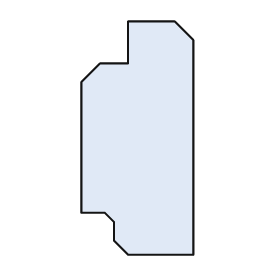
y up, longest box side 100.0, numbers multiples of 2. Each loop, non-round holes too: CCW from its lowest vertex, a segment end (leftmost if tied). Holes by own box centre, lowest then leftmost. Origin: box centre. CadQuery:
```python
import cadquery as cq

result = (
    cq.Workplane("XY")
    .moveTo(-4.0, -50.0)
    .lineTo(24.0, -50.0)
    .lineTo(24.0, 42.0)
    .lineTo(16.0, 50.0)
    .lineTo(-4.0, 50.0)
    .lineTo(-4.0, 32.0)
    .lineTo(-16.0, 32.0)
    .lineTo(-24.0, 24.0)
    .lineTo(-24.0, -32.0)
    .lineTo(-14.0, -32.0)
    .lineTo(-10.0, -36.0)
    .lineTo(-10.0, -44.0)
    .close()
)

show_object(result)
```